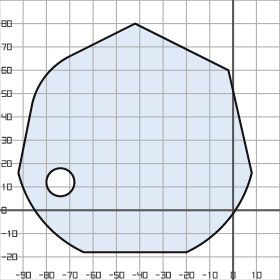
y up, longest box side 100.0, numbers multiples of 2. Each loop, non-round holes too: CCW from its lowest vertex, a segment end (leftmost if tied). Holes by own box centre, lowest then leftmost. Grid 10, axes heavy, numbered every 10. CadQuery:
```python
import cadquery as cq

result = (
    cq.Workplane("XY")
    .moveTo(-64.0, -18.0)
    .lineTo(-20.0, -18.0)
    .threePointArc((-2.0, -4.0), (8.0, 16.0))
    .lineTo(-2.0, 60.0)
    .lineTo(-42.0, 80.0)
    .lineTo(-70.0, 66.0)
    .threePointArc((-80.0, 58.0), (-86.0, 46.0))
    .lineTo(-92.0, 16.0)
    .threePointArc((-82.0, -4.0), (-64.0, -18.0))
    .close()
    .moveTo(-74.0, 12.0)
    .circle(6.0)
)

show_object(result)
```